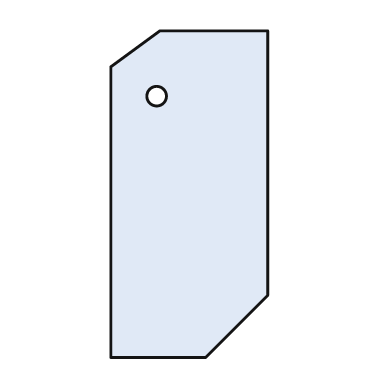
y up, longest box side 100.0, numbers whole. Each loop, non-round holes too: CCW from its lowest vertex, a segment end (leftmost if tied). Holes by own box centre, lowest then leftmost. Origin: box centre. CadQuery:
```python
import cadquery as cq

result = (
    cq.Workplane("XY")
    .moveTo(-24.0, -50.0)
    .lineTo(5.0, -50.0)
    .lineTo(24.0, -31.0)
    .lineTo(24.0, 50.0)
    .lineTo(-9.0, 50.0)
    .lineTo(-24.0, 39.0)
    .close()
    .moveTo(-10.0, 30.0)
    .circle(3.0)
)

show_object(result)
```